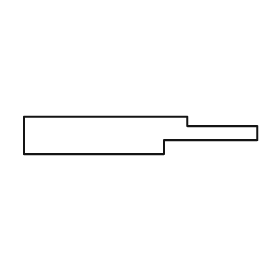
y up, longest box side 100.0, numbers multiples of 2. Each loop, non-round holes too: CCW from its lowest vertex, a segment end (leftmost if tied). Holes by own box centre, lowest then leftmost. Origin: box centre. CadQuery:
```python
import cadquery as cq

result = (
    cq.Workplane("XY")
    .moveTo(-50.0, -8.0)
    .lineTo(10.0, -8.0)
    .lineTo(10.0, -2.0)
    .lineTo(50.0, -2.0)
    .lineTo(50.0, 4.0)
    .lineTo(20.0, 4.0)
    .lineTo(20.0, 8.0)
    .lineTo(-50.0, 8.0)
    .close()
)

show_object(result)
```